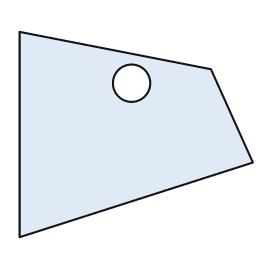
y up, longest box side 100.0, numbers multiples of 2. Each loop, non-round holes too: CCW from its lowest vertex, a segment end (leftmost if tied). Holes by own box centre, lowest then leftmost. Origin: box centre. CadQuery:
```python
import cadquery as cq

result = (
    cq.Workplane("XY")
    .moveTo(-50.0, -44.0)
    .lineTo(50.0, -12.0)
    .lineTo(32.0, 28.0)
    .lineTo(-50.0, 44.0)
    .close()
    .moveTo(-2.0, 22.0)
    .circle(8.0)
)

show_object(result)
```